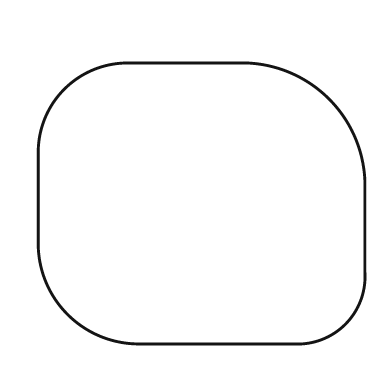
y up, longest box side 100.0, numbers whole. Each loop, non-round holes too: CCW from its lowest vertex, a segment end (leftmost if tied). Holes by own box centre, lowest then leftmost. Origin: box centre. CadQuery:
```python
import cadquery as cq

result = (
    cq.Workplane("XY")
    .moveTo(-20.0, -43.0)
    .lineTo(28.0, -43.0)
    .threePointArc((44.0, -37.0), (50.0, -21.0))
    .lineTo(50.0, 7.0)
    .threePointArc((39.0, 32.0), (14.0, 43.0))
    .lineTo(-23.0, 43.0)
    .threePointArc((-42.0, 35.0), (-50.0, 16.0))
    .lineTo(-50.0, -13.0)
    .threePointArc((-41.0, -34.0), (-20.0, -43.0))
    .close()
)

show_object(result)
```